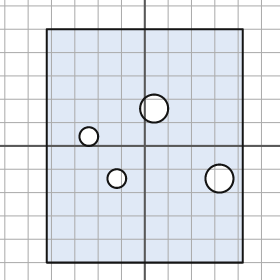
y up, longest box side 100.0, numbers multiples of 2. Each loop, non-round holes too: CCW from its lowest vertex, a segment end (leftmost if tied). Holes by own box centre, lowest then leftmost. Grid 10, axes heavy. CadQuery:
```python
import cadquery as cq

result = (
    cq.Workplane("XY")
    .moveTo(-42.0, -50.0)
    .lineTo(42.0, -50.0)
    .lineTo(42.0, 50.0)
    .lineTo(-42.0, 50.0)
    .close()
    .moveTo(-12.0, -14.0)
    .circle(4.0)
    .moveTo(32.0, -14.0)
    .circle(6.0)
    .moveTo(-24.0, 4.0)
    .circle(4.0)
    .moveTo(4.0, 16.0)
    .circle(6.0)
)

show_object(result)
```